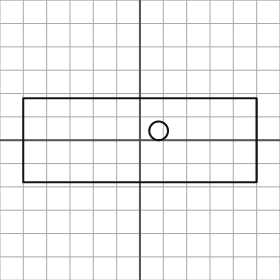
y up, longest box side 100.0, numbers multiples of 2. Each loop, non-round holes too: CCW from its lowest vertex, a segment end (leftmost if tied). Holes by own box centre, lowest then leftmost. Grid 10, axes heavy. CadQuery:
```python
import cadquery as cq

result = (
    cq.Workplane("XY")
    .moveTo(-50.0, -18.0)
    .lineTo(50.0, -18.0)
    .lineTo(50.0, 18.0)
    .lineTo(-50.0, 18.0)
    .close()
    .moveTo(8.0, 4.0)
    .circle(4.0)
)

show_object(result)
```